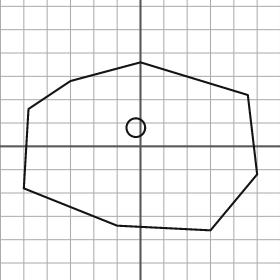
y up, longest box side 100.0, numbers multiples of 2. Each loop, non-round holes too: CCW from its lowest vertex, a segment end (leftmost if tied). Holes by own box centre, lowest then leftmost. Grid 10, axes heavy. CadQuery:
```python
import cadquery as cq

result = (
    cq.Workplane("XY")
    .moveTo(30.0, -36.0)
    .lineTo(50.0, -12.0)
    .lineTo(46.0, 22.0)
    .lineTo(0.0, 36.0)
    .lineTo(-30.0, 28.0)
    .lineTo(-48.0, 16.0)
    .lineTo(-50.0, -18.0)
    .lineTo(-10.0, -34.0)
    .close()
    .moveTo(-2.0, 8.0)
    .circle(4.0)
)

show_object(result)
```